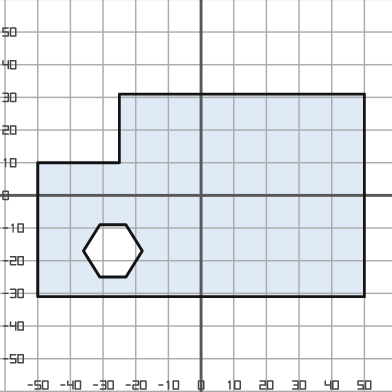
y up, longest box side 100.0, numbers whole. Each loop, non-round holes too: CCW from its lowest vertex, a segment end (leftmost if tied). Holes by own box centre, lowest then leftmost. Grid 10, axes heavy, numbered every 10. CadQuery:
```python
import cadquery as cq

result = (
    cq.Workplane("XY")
    .moveTo(-50.0, -31.0)
    .lineTo(50.0, -31.0)
    .lineTo(50.0, 31.0)
    .lineTo(-25.0, 31.0)
    .lineTo(-25.0, 10.0)
    .lineTo(-50.0, 10.0)
    .close()
    .moveTo(-31.0, -25.0)
    .lineTo(-23.0, -25.0)
    .lineTo(-18.0, -17.0)
    .lineTo(-23.0, -9.0)
    .lineTo(-31.0, -9.0)
    .lineTo(-36.0, -17.0)
    .close()
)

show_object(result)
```